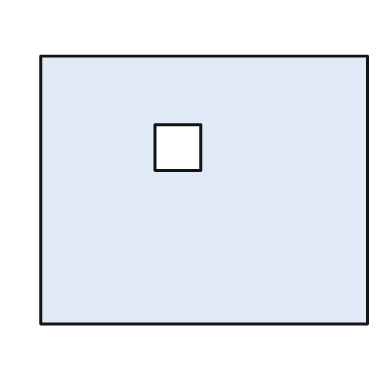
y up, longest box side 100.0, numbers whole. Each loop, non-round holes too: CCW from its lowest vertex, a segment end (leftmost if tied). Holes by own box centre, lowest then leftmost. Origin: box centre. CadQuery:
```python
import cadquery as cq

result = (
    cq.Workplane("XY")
    .moveTo(-50.0, -41.0)
    .lineTo(50.0, -41.0)
    .lineTo(50.0, 41.0)
    .lineTo(-50.0, 41.0)
    .close()
    .moveTo(-15.0, 6.0)
    .lineTo(-1.0, 6.0)
    .lineTo(-1.0, 20.0)
    .lineTo(-15.0, 20.0)
    .close()
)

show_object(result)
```